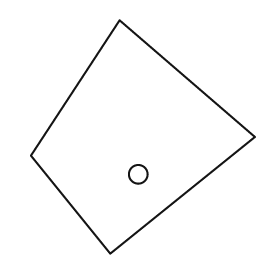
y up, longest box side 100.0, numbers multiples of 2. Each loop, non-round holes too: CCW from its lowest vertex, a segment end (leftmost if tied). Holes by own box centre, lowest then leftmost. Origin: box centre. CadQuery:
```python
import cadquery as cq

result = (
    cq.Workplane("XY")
    .moveTo(-14.0, -50.0)
    .lineTo(48.0, 0.0)
    .lineTo(-10.0, 50.0)
    .lineTo(-48.0, -8.0)
    .close()
    .moveTo(-2.0, -16.0)
    .circle(4.0)
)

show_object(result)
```